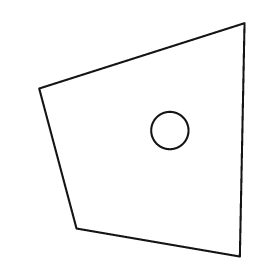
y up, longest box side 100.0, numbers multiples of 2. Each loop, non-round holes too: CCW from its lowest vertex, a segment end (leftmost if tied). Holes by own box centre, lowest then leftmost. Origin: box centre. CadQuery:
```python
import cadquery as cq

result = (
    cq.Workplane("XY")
    .moveTo(42.0, -50.0)
    .lineTo(44.0, 50.0)
    .lineTo(-44.0, 22.0)
    .lineTo(-28.0, -38.0)
    .close()
    .moveTo(12.0, 4.0)
    .circle(8.0)
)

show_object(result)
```